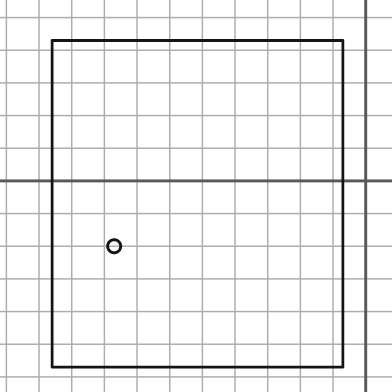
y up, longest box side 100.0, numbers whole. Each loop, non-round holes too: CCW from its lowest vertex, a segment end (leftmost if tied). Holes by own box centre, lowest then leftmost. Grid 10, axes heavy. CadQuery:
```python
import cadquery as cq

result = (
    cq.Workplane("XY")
    .moveTo(-96.0, -57.0)
    .lineTo(-7.0, -57.0)
    .lineTo(-7.0, 43.0)
    .lineTo(-96.0, 43.0)
    .close()
    .moveTo(-77.0, -20.0)
    .circle(2.0)
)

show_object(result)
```